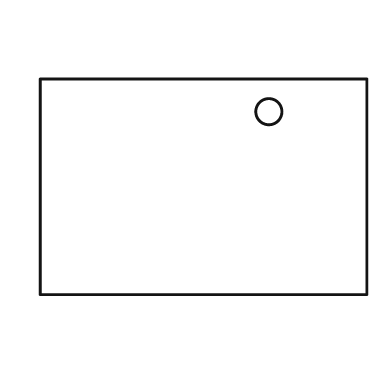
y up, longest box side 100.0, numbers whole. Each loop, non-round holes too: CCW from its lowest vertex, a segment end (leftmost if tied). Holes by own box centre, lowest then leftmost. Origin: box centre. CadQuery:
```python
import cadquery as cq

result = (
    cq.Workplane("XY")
    .moveTo(-50.0, -33.0)
    .lineTo(50.0, -33.0)
    .lineTo(50.0, 33.0)
    .lineTo(-50.0, 33.0)
    .close()
    .moveTo(20.0, 23.0)
    .circle(4.0)
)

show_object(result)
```